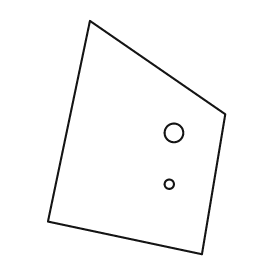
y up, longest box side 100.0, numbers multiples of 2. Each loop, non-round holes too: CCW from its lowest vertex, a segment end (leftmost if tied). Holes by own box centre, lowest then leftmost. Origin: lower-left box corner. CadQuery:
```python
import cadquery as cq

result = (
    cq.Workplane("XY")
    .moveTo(66.0, 0.0)
    .lineTo(76.0, 60.0)
    .lineTo(18.0, 100.0)
    .lineTo(0.0, 14.0)
    .close()
    .moveTo(52.0, 30.0)
    .circle(2.0)
    .moveTo(54.0, 52.0)
    .circle(4.0)
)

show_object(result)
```